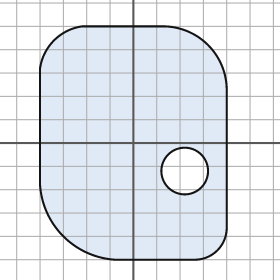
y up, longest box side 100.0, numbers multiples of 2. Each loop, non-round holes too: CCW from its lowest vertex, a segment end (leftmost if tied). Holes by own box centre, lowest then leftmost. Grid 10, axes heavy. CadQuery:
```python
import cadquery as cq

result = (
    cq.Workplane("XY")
    .moveTo(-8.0, -50.0)
    .lineTo(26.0, -50.0)
    .threePointArc((36.0, -46.0), (40.0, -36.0))
    .lineTo(40.0, 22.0)
    .threePointArc((32.0, 42.0), (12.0, 50.0))
    .lineTo(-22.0, 50.0)
    .threePointArc((-34.0, 44.0), (-40.0, 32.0))
    .lineTo(-40.0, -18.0)
    .threePointArc((-30.0, -40.0), (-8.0, -50.0))
    .close()
    .moveTo(22.0, -12.0)
    .circle(10.0)
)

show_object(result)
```